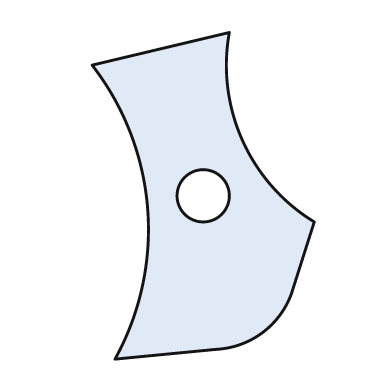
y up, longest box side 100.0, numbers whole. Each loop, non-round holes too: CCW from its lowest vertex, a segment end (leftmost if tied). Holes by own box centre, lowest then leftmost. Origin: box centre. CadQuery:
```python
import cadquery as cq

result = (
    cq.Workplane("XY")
    .moveTo(-27.0, -50.0)
    .lineTo(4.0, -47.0)
    .threePointArc((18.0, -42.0), (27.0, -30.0))
    .lineTo(34.0, -8.0)
    .threePointArc((12.0, 17.0), (8.0, 50.0))
    .lineTo(-34.0, 40.0)
    .threePointArc((-17.0, -4.0), (-27.0, -50.0))
    .close()
    .moveTo(0.0, 0.0)
    .circle(8.0)
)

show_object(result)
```